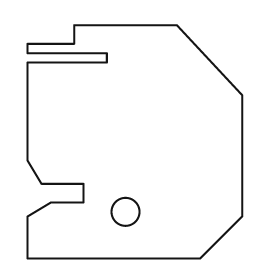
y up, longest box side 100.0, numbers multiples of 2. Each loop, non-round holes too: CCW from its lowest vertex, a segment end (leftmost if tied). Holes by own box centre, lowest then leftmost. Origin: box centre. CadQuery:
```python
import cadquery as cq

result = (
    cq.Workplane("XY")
    .moveTo(-46.0, -50.0)
    .lineTo(28.0, -50.0)
    .lineTo(46.0, -32.0)
    .lineTo(46.0, 20.0)
    .lineTo(18.0, 50.0)
    .lineTo(-26.0, 50.0)
    .lineTo(-26.0, 42.0)
    .lineTo(-46.0, 42.0)
    .lineTo(-46.0, 38.0)
    .lineTo(-12.0, 38.0)
    .lineTo(-12.0, 34.0)
    .lineTo(-46.0, 34.0)
    .lineTo(-46.0, -8.0)
    .lineTo(-40.0, -18.0)
    .lineTo(-22.0, -18.0)
    .lineTo(-22.0, -26.0)
    .lineTo(-36.0, -26.0)
    .lineTo(-46.0, -32.0)
    .close()
    .moveTo(-4.0, -30.0)
    .circle(6.0)
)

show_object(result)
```